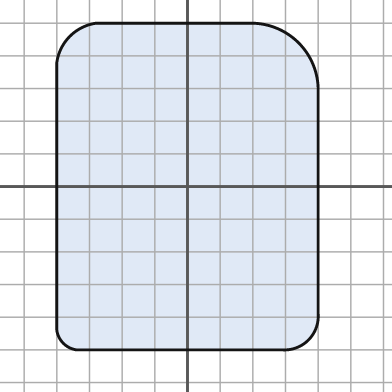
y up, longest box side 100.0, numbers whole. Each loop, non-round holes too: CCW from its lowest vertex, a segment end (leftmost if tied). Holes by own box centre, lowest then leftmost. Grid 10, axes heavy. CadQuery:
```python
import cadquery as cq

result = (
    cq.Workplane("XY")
    .moveTo(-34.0, -50.0)
    .lineTo(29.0, -50.0)
    .threePointArc((37.0, -47.0), (40.0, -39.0))
    .lineTo(40.0, 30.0)
    .threePointArc((34.0, 44.0), (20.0, 50.0))
    .lineTo(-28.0, 50.0)
    .threePointArc((-36.0, 46.0), (-40.0, 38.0))
    .lineTo(-40.0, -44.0)
    .threePointArc((-38.0, -48.0), (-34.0, -50.0))
    .close()
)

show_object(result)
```